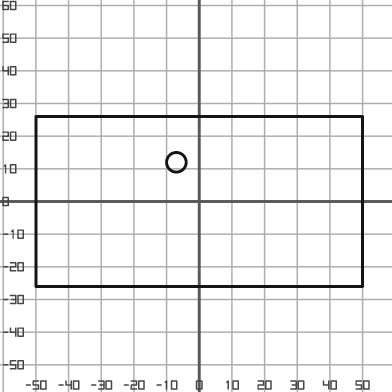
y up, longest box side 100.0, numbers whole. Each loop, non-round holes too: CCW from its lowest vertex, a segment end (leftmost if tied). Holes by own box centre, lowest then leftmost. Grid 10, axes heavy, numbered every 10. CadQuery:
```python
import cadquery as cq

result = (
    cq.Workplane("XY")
    .moveTo(-50.0, -26.0)
    .lineTo(50.0, -26.0)
    .lineTo(50.0, 26.0)
    .lineTo(-50.0, 26.0)
    .close()
    .moveTo(-7.0, 12.0)
    .circle(3.0)
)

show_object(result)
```